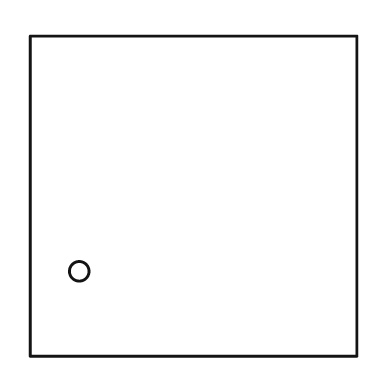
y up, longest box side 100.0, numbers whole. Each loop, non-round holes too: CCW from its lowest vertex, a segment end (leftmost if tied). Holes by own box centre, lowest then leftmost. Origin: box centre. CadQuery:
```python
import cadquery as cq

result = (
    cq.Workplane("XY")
    .moveTo(-50.0, -49.0)
    .lineTo(50.0, -49.0)
    .lineTo(50.0, 49.0)
    .lineTo(-50.0, 49.0)
    .close()
    .moveTo(-35.0, -23.0)
    .circle(3.0)
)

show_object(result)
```